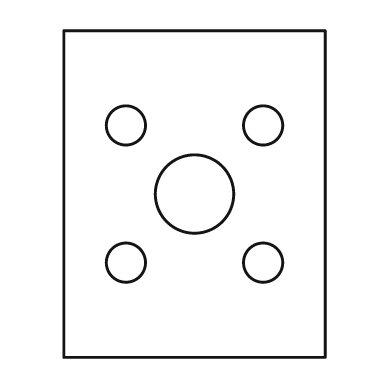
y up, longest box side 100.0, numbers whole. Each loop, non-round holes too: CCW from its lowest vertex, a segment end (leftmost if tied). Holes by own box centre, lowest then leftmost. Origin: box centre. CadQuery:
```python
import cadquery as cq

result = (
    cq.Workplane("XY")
    .moveTo(-40.0, -50.0)
    .lineTo(40.0, -50.0)
    .lineTo(40.0, 50.0)
    .lineTo(-40.0, 50.0)
    .close()
    .moveTo(-21.0, -21.0)
    .circle(6.0)
    .moveTo(21.0, -21.0)
    .circle(6.0)
    .moveTo(0.0, 0.0)
    .circle(12.0)
    .moveTo(-21.0, 21.0)
    .circle(6.0)
    .moveTo(21.0, 21.0)
    .circle(6.0)
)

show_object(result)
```